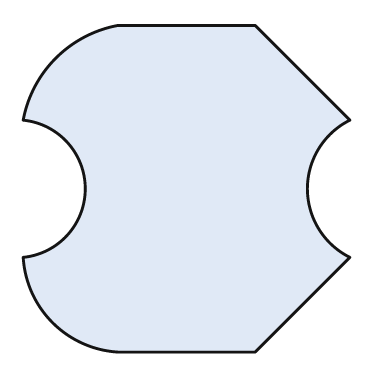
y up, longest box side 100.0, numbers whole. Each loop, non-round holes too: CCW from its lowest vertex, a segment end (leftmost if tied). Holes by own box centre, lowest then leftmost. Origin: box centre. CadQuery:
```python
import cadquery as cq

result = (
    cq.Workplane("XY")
    .moveTo(-21.0, -50.0)
    .lineTo(21.0, -50.0)
    .lineTo(50.0, -21.0)
    .threePointArc((37.0, 0.0), (50.0, 21.0))
    .lineTo(21.0, 50.0)
    .lineTo(-21.0, 50.0)
    .threePointArc((-40.0, 40.0), (-50.0, 21.0))
    .threePointArc((-31.0, 0.0), (-50.0, -21.0))
    .threePointArc((-41.0, -41.0), (-21.0, -50.0))
    .close()
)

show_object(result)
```